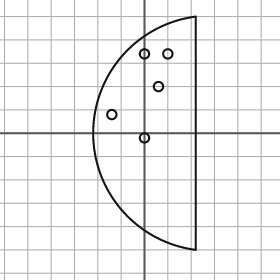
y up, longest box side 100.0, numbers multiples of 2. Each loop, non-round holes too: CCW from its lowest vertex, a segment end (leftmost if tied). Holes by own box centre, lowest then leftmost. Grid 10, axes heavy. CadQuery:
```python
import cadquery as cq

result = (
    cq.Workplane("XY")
    .moveTo(22.0, -50.0)
    .lineTo(22.0, 50.0)
    .threePointArc((-22.0, 0.0), (22.0, -50.0))
    .close()
    .moveTo(0.0, -2.0)
    .circle(2.0)
    .moveTo(-14.0, 8.0)
    .circle(2.0)
    .moveTo(6.0, 20.0)
    .circle(2.0)
    .moveTo(0.0, 34.0)
    .circle(2.0)
    .moveTo(10.0, 34.0)
    .circle(2.0)
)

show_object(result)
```